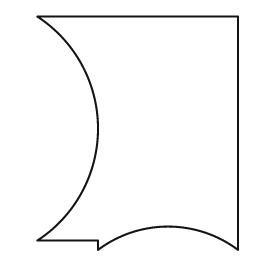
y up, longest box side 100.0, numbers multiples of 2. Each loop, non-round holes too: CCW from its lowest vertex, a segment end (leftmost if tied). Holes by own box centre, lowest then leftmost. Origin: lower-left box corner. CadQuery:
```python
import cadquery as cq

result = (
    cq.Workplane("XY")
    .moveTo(26.0, 0.0)
    .threePointArc((56.0, 10.0), (86.0, 0.0))
    .lineTo(86.0, 100.0)
    .lineTo(0.0, 100.0)
    .threePointArc((26.0, 52.0), (0.0, 4.0))
    .lineTo(26.0, 4.0)
    .close()
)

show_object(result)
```